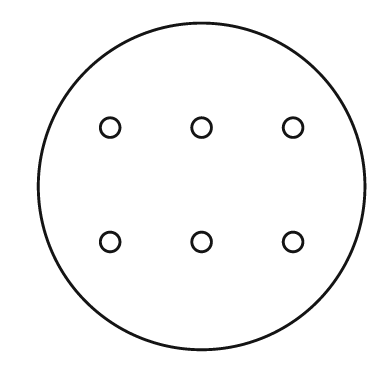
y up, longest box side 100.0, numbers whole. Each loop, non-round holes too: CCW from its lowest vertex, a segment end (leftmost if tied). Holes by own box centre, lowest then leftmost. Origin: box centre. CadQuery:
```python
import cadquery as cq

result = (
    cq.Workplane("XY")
    .moveTo(0.0, 0.0)
    .circle(50.0)
    .moveTo(-28.0, -17.0)
    .circle(3.0)
    .moveTo(0.0, -17.0)
    .circle(3.0)
    .moveTo(28.0, -17.0)
    .circle(3.0)
    .moveTo(-28.0, 18.0)
    .circle(3.0)
    .moveTo(0.0, 18.0)
    .circle(3.0)
    .moveTo(28.0, 18.0)
    .circle(3.0)
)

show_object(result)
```